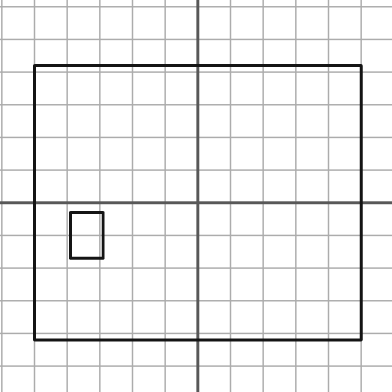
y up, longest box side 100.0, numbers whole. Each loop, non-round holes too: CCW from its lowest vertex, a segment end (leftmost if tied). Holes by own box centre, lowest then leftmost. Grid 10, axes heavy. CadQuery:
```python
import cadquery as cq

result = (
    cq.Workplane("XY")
    .moveTo(-50.0, -42.0)
    .lineTo(50.0, -42.0)
    .lineTo(50.0, 42.0)
    .lineTo(-50.0, 42.0)
    .close()
    .moveTo(-39.0, -17.0)
    .lineTo(-29.0, -17.0)
    .lineTo(-29.0, -3.0)
    .lineTo(-39.0, -3.0)
    .close()
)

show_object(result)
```